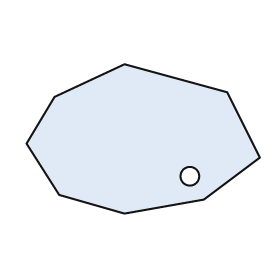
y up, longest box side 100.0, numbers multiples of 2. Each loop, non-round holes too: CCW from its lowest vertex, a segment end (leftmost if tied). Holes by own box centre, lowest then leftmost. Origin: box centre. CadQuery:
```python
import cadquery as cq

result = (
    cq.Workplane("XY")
    .moveTo(-8.0, -32.0)
    .lineTo(26.0, -26.0)
    .lineTo(50.0, -8.0)
    .lineTo(36.0, 20.0)
    .lineTo(-8.0, 32.0)
    .lineTo(-38.0, 18.0)
    .lineTo(-50.0, -2.0)
    .lineTo(-36.0, -24.0)
    .close()
    .moveTo(20.0, -16.0)
    .circle(4.0)
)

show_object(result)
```